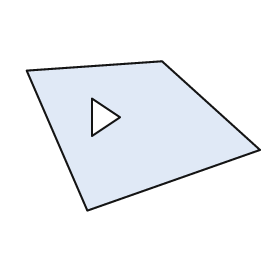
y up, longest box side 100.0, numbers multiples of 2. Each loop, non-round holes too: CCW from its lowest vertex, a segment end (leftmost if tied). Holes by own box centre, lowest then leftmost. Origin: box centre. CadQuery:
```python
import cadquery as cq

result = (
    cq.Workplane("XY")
    .moveTo(-24.0, -32.0)
    .lineTo(50.0, -6.0)
    .lineTo(8.0, 32.0)
    .lineTo(-50.0, 28.0)
    .close()
    .moveTo(-22.0, 0.0)
    .lineTo(-10.0, 8.0)
    .lineTo(-22.0, 16.0)
    .close()
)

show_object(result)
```